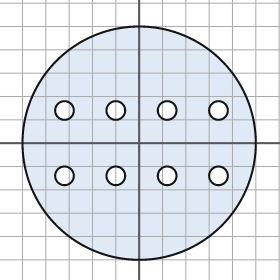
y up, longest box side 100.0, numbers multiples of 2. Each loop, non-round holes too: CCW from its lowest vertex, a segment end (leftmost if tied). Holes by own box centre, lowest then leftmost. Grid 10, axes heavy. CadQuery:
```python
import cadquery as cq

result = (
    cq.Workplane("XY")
    .moveTo(0.0, 0.0)
    .circle(50.0)
    .moveTo(-32.0, -14.0)
    .circle(4.0)
    .moveTo(-10.0, -14.0)
    .circle(4.0)
    .moveTo(12.0, -14.0)
    .circle(4.0)
    .moveTo(34.0, -14.0)
    .circle(4.0)
    .moveTo(-32.0, 14.0)
    .circle(4.0)
    .moveTo(-10.0, 14.0)
    .circle(4.0)
    .moveTo(12.0, 14.0)
    .circle(4.0)
    .moveTo(34.0, 14.0)
    .circle(4.0)
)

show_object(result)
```